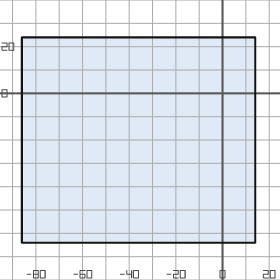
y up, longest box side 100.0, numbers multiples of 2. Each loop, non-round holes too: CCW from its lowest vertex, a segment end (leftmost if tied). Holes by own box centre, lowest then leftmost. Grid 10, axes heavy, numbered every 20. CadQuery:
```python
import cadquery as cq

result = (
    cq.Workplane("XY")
    .moveTo(-86.0, -64.0)
    .lineTo(14.0, -64.0)
    .lineTo(14.0, 24.0)
    .lineTo(-86.0, 24.0)
    .close()
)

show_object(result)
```